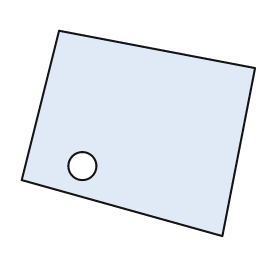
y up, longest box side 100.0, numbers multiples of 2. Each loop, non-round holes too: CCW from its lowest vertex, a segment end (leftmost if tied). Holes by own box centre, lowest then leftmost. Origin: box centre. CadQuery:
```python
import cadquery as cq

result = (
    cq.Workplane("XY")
    .moveTo(36.0, -44.0)
    .lineTo(50.0, 28.0)
    .lineTo(-34.0, 44.0)
    .lineTo(-50.0, -20.0)
    .close()
    .moveTo(-24.0, -14.0)
    .circle(6.0)
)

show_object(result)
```